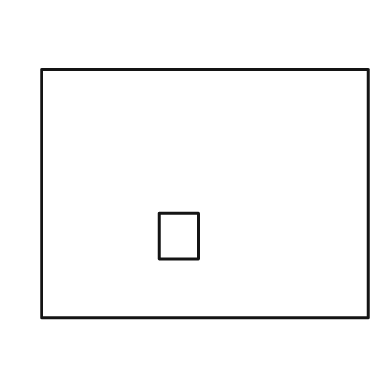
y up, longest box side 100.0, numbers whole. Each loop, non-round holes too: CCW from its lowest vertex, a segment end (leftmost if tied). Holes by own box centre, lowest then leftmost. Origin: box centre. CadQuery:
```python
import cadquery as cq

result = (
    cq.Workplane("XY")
    .moveTo(-50.0, -38.0)
    .lineTo(50.0, -38.0)
    .lineTo(50.0, 38.0)
    .lineTo(-50.0, 38.0)
    .close()
    .moveTo(-14.0, -20.0)
    .lineTo(-2.0, -20.0)
    .lineTo(-2.0, -6.0)
    .lineTo(-14.0, -6.0)
    .close()
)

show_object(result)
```